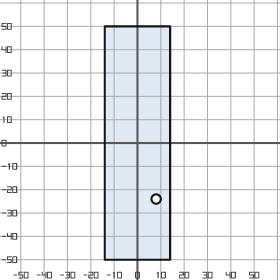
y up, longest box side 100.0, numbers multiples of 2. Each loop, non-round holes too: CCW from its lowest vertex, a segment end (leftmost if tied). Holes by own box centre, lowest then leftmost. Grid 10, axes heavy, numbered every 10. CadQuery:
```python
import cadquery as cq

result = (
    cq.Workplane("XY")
    .moveTo(-14.0, -50.0)
    .lineTo(14.0, -50.0)
    .lineTo(14.0, 50.0)
    .lineTo(-14.0, 50.0)
    .close()
    .moveTo(8.0, -24.0)
    .circle(2.0)
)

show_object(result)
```